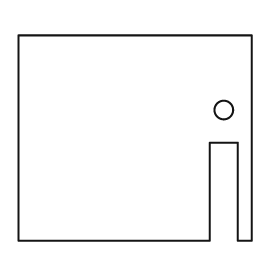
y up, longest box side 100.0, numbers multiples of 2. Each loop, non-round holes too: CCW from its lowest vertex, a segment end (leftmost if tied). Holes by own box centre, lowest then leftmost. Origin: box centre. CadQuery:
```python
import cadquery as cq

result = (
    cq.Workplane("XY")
    .moveTo(-50.0, -44.0)
    .lineTo(32.0, -44.0)
    .lineTo(32.0, -2.0)
    .lineTo(44.0, -2.0)
    .lineTo(44.0, -44.0)
    .lineTo(50.0, -44.0)
    .lineTo(50.0, 44.0)
    .lineTo(-50.0, 44.0)
    .close()
    .moveTo(38.0, 12.0)
    .circle(4.0)
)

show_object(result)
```